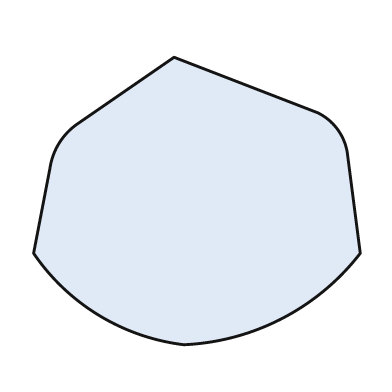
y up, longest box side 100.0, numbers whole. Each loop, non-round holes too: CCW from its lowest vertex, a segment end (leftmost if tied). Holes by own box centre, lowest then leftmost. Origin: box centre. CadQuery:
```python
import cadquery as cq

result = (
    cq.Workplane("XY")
    .moveTo(-4.0, -44.0)
    .threePointArc((26.0, -36.0), (50.0, -16.0))
    .lineTo(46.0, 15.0)
    .threePointArc((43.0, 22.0), (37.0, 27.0))
    .lineTo(-7.0, 44.0)
    .lineTo(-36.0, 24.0)
    .threePointArc((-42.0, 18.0), (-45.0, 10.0))
    .lineTo(-50.0, -16.0)
    .threePointArc((-30.0, -35.0), (-4.0, -44.0))
    .close()
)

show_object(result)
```